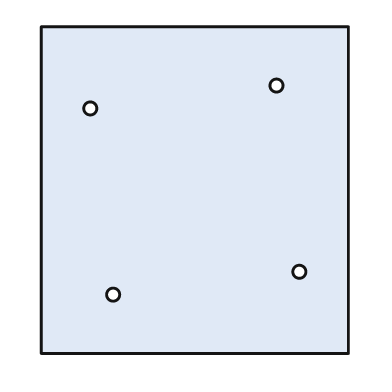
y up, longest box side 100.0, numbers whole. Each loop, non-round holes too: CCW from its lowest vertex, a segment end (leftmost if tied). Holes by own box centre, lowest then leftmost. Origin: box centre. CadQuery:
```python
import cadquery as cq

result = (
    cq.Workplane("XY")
    .moveTo(-47.0, -50.0)
    .lineTo(47.0, -50.0)
    .lineTo(47.0, 50.0)
    .lineTo(-47.0, 50.0)
    .close()
    .moveTo(-25.0, -32.0)
    .circle(2.0)
    .moveTo(32.0, -25.0)
    .circle(2.0)
    .moveTo(-32.0, 25.0)
    .circle(2.0)
    .moveTo(25.0, 32.0)
    .circle(2.0)
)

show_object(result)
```